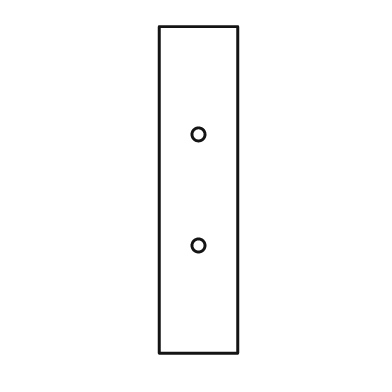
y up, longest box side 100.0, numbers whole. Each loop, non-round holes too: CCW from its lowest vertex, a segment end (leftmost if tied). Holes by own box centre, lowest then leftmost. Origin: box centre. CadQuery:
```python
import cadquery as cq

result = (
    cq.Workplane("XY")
    .moveTo(-12.0, -50.0)
    .lineTo(12.0, -50.0)
    .lineTo(12.0, 50.0)
    .lineTo(-12.0, 50.0)
    .close()
    .moveTo(0.0, -17.0)
    .circle(2.0)
    .moveTo(0.0, 17.0)
    .circle(2.0)
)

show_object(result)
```